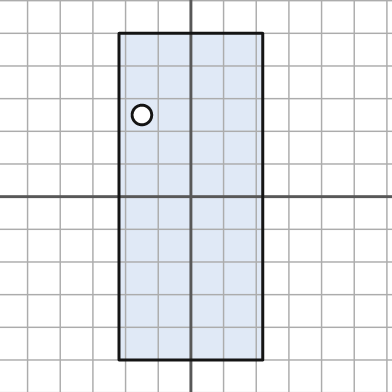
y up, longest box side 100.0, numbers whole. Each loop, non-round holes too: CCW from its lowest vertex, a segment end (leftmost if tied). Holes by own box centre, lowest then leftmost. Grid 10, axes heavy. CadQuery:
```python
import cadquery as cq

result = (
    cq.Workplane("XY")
    .moveTo(-22.0, -50.0)
    .lineTo(22.0, -50.0)
    .lineTo(22.0, 50.0)
    .lineTo(-22.0, 50.0)
    .close()
    .moveTo(-15.0, 25.0)
    .circle(3.0)
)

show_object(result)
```